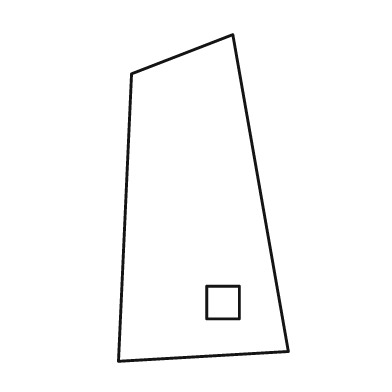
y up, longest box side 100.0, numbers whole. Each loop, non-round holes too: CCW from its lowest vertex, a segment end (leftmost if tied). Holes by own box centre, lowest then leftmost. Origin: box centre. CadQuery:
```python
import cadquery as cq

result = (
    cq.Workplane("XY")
    .moveTo(-26.0, -50.0)
    .lineTo(26.0, -47.0)
    .lineTo(9.0, 50.0)
    .lineTo(-22.0, 38.0)
    .close()
    .moveTo(1.0, -37.0)
    .lineTo(11.0, -37.0)
    .lineTo(11.0, -27.0)
    .lineTo(1.0, -27.0)
    .close()
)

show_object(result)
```